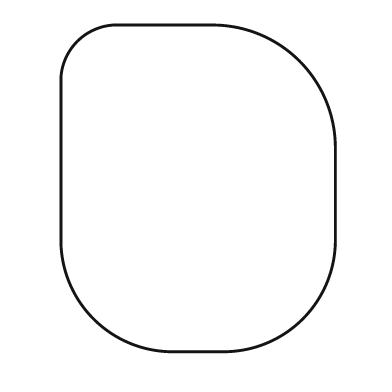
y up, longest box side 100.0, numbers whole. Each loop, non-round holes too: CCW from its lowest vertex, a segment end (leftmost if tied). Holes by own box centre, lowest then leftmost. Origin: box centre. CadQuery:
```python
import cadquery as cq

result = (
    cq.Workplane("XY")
    .moveTo(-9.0, -50.0)
    .lineTo(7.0, -50.0)
    .threePointArc((32.0, -40.0), (42.0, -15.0))
    .lineTo(42.0, 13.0)
    .threePointArc((31.0, 39.0), (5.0, 50.0))
    .lineTo(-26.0, 50.0)
    .threePointArc((-37.0, 45.0), (-42.0, 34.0))
    .lineTo(-42.0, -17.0)
    .threePointArc((-32.0, -40.0), (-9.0, -50.0))
    .close()
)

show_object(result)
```